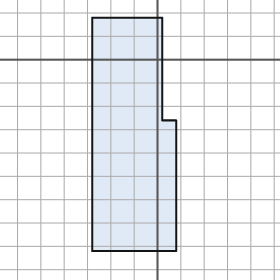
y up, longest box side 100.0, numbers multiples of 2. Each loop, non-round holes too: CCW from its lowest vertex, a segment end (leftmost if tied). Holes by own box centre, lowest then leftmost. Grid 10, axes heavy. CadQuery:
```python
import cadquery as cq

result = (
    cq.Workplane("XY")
    .moveTo(-28.0, -82.0)
    .lineTo(8.0, -82.0)
    .lineTo(8.0, -26.0)
    .lineTo(2.0, -26.0)
    .lineTo(2.0, 18.0)
    .lineTo(-28.0, 18.0)
    .close()
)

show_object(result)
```